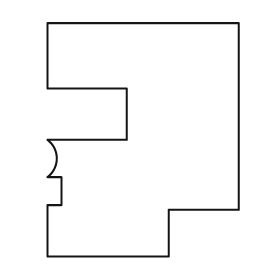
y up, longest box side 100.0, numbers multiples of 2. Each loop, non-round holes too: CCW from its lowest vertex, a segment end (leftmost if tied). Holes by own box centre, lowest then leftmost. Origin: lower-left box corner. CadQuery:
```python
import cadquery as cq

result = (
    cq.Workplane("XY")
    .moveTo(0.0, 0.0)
    .lineTo(52.0, 0.0)
    .lineTo(52.0, 20.0)
    .lineTo(82.0, 20.0)
    .lineTo(82.0, 100.0)
    .lineTo(0.0, 100.0)
    .lineTo(0.0, 72.0)
    .lineTo(34.0, 72.0)
    .lineTo(34.0, 50.0)
    .lineTo(0.0, 50.0)
    .threePointArc((4.0, 42.0), (0.0, 34.0))
    .lineTo(6.0, 34.0)
    .lineTo(6.0, 22.0)
    .lineTo(0.0, 22.0)
    .close()
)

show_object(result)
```